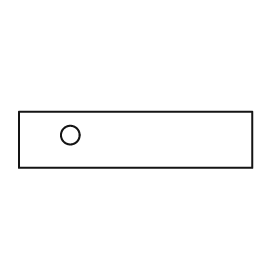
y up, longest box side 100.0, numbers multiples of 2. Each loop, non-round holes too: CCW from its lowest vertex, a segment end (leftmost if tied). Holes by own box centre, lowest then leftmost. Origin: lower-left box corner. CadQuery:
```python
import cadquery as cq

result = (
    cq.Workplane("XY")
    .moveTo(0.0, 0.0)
    .lineTo(100.0, 0.0)
    .lineTo(100.0, 24.0)
    .lineTo(0.0, 24.0)
    .close()
    .moveTo(22.0, 14.0)
    .circle(4.0)
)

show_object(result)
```